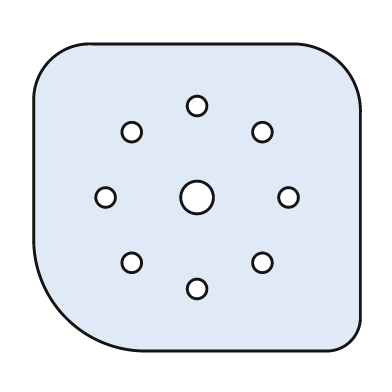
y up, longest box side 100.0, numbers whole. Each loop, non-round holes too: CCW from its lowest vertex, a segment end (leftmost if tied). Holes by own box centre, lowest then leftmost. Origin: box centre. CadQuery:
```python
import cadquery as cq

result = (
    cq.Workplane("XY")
    .moveTo(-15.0, -47.0)
    .lineTo(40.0, -47.0)
    .threePointArc((47.0, -44.0), (50.0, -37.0))
    .lineTo(50.0, 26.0)
    .threePointArc((44.0, 41.0), (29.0, 47.0))
    .lineTo(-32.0, 47.0)
    .threePointArc((-45.0, 42.0), (-50.0, 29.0))
    .lineTo(-50.0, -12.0)
    .threePointArc((-40.0, -37.0), (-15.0, -47.0))
    .close()
    .moveTo(0.0, -28.0)
    .circle(3.0)
    .moveTo(-20.0, -20.0)
    .circle(3.0)
    .moveTo(20.0, -20.0)
    .circle(3.0)
    .moveTo(-28.0, 0.0)
    .circle(3.0)
    .moveTo(0.0, 0.0)
    .circle(5.0)
    .moveTo(28.0, 0.0)
    .circle(3.0)
    .moveTo(-20.0, 20.0)
    .circle(3.0)
    .moveTo(20.0, 20.0)
    .circle(3.0)
    .moveTo(0.0, 28.0)
    .circle(3.0)
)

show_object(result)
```